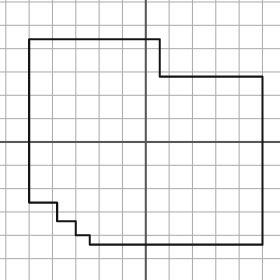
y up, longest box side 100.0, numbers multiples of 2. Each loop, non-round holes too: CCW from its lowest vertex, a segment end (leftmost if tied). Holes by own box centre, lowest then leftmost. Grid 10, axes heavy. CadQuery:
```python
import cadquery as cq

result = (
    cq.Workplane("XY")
    .moveTo(-24.0, -44.0)
    .lineTo(50.0, -44.0)
    .lineTo(50.0, 28.0)
    .lineTo(6.0, 28.0)
    .lineTo(6.0, 44.0)
    .lineTo(-50.0, 44.0)
    .lineTo(-50.0, -26.0)
    .lineTo(-38.0, -26.0)
    .lineTo(-38.0, -34.0)
    .lineTo(-30.0, -34.0)
    .lineTo(-30.0, -40.0)
    .lineTo(-24.0, -40.0)
    .close()
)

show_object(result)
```